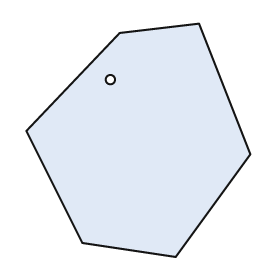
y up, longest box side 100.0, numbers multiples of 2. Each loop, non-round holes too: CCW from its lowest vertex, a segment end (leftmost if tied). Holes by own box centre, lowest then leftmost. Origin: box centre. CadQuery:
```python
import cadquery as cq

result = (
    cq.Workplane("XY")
    .moveTo(16.0, -50.0)
    .lineTo(48.0, -6.0)
    .lineTo(26.0, 50.0)
    .lineTo(-8.0, 46.0)
    .lineTo(-48.0, 4.0)
    .lineTo(-24.0, -44.0)
    .close()
    .moveTo(-12.0, 26.0)
    .circle(2.0)
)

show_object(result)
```